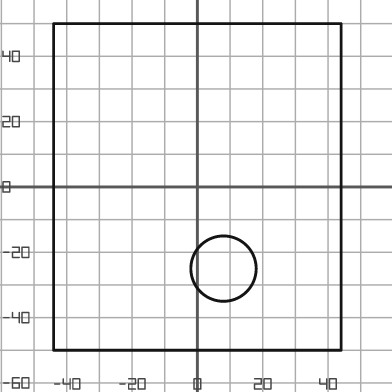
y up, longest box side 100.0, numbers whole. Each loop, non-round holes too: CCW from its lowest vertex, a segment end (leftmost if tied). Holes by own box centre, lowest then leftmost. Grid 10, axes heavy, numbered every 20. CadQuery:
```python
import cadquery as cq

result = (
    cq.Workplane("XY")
    .moveTo(-44.0, -50.0)
    .lineTo(44.0, -50.0)
    .lineTo(44.0, 50.0)
    .lineTo(-44.0, 50.0)
    .close()
    .moveTo(8.0, -25.0)
    .circle(10.0)
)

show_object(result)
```